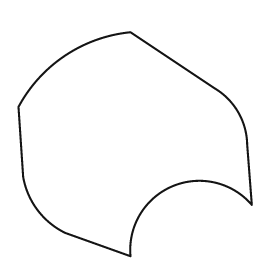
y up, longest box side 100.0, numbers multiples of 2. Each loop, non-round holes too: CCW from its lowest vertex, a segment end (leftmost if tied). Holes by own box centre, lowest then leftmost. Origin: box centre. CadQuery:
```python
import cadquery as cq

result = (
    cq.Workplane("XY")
    .moveTo(-2.0, -48.0)
    .threePointArc((16.0, -18.0), (50.0, -26.0))
    .lineTo(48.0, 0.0)
    .threePointArc((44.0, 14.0), (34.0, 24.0))
    .lineTo(-2.0, 48.0)
    .threePointArc((-30.0, 38.0), (-50.0, 16.0))
    .lineTo(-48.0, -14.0)
    .threePointArc((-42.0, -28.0), (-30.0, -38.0))
    .close()
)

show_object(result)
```